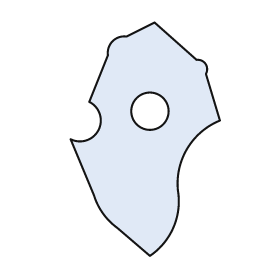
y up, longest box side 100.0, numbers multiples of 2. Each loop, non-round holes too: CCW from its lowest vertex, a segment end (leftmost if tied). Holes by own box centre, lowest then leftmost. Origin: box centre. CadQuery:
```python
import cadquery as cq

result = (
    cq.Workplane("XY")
    .moveTo(2.0, -50.0)
    .threePointArc((12.0, -38.0), (14.0, -22.0))
    .threePointArc((18.0, -4.0), (32.0, 8.0))
    .lineTo(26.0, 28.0)
    .threePointArc((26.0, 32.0), (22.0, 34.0))
    .lineTo(4.0, 50.0)
    .lineTo(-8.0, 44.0)
    .threePointArc((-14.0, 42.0), (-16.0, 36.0))
    .lineTo(-24.0, 16.0)
    .threePointArc((-20.0, 4.0), (-32.0, 0.0))
    .lineTo(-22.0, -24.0)
    .threePointArc((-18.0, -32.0), (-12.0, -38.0))
    .close()
    .moveTo(2.0, 12.0)
    .circle(8.0)
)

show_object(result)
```